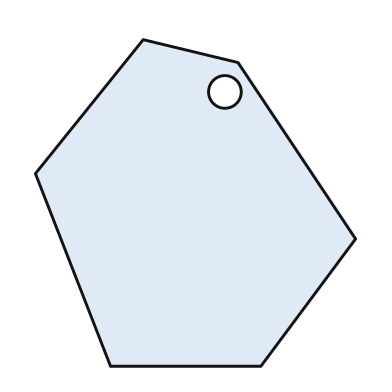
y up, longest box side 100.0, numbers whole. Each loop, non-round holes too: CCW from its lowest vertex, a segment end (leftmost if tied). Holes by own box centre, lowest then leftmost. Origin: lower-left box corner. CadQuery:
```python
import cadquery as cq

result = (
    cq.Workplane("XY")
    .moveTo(23.0, 0.0)
    .lineTo(69.0, 0.0)
    .lineTo(98.0, 39.0)
    .lineTo(62.0, 93.0)
    .lineTo(33.0, 100.0)
    .lineTo(0.0, 59.0)
    .close()
    .moveTo(58.0, 84.0)
    .circle(5.0)
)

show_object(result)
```